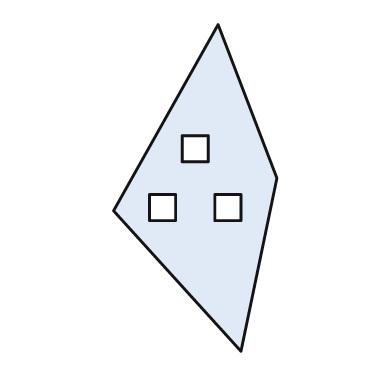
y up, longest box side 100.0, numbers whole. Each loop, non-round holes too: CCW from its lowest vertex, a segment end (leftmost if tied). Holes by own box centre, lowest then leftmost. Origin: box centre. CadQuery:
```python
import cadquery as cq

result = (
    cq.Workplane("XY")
    .moveTo(14.0, -50.0)
    .lineTo(25.0, 3.0)
    .lineTo(7.0, 50.0)
    .lineTo(-25.0, -7.0)
    .close()
    .moveTo(-14.0, -10.0)
    .lineTo(-6.0, -10.0)
    .lineTo(-6.0, -2.0)
    .lineTo(-14.0, -2.0)
    .close()
    .moveTo(6.0, -10.0)
    .lineTo(14.0, -10.0)
    .lineTo(14.0, -2.0)
    .lineTo(6.0, -2.0)
    .close()
    .moveTo(-4.0, 8.0)
    .lineTo(4.0, 8.0)
    .lineTo(4.0, 16.0)
    .lineTo(-4.0, 16.0)
    .close()
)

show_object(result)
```